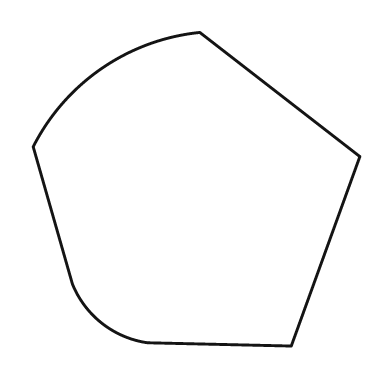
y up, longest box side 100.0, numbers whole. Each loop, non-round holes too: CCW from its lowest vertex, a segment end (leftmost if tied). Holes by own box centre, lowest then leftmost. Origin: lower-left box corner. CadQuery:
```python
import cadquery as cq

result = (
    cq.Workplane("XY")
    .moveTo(79.0, 0.0)
    .lineTo(100.0, 58.0)
    .lineTo(51.0, 96.0)
    .threePointArc((21.0, 85.0), (0.0, 61.0))
    .lineTo(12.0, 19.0)
    .threePointArc((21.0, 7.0), (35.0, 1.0))
    .close()
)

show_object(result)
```